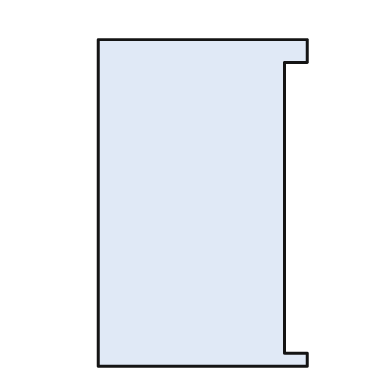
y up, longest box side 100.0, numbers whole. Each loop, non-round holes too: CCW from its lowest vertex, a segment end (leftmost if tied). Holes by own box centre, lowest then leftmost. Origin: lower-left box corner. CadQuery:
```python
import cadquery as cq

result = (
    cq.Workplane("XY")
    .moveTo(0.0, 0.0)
    .lineTo(64.0, 0.0)
    .lineTo(64.0, 4.0)
    .lineTo(57.0, 4.0)
    .lineTo(57.0, 93.0)
    .lineTo(64.0, 93.0)
    .lineTo(64.0, 100.0)
    .lineTo(0.0, 100.0)
    .close()
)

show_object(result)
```